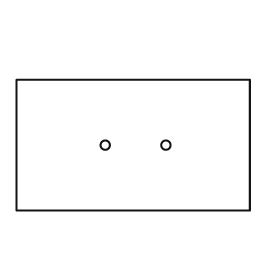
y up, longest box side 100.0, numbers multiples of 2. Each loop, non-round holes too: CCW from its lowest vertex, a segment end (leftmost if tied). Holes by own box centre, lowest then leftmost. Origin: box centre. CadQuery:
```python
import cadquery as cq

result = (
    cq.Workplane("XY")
    .moveTo(-50.0, -28.0)
    .lineTo(50.0, -28.0)
    .lineTo(50.0, 28.0)
    .lineTo(-50.0, 28.0)
    .close()
    .moveTo(-12.0, 0.0)
    .circle(2.0)
    .moveTo(14.0, 0.0)
    .circle(2.0)
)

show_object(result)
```